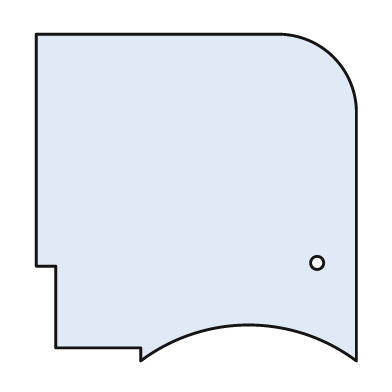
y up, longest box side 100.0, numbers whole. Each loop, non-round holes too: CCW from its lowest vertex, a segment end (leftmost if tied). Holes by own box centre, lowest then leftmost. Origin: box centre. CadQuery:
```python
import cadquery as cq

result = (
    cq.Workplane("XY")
    .moveTo(-17.0, -50.0)
    .threePointArc((16.0, -39.0), (49.0, -50.0))
    .lineTo(49.0, 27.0)
    .threePointArc((42.0, 43.0), (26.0, 50.0))
    .lineTo(-49.0, 50.0)
    .lineTo(-49.0, -21.0)
    .lineTo(-43.0, -21.0)
    .lineTo(-43.0, -46.0)
    .lineTo(-17.0, -46.0)
    .close()
    .moveTo(37.0, -20.0)
    .circle(2.0)
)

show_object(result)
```